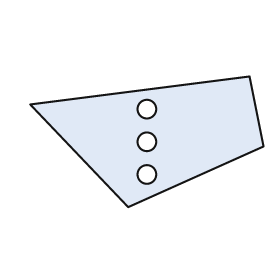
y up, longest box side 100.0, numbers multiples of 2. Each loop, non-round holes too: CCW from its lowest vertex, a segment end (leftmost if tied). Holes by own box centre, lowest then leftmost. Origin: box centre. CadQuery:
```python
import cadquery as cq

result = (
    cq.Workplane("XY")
    .moveTo(-8.0, -28.0)
    .lineTo(50.0, -2.0)
    .lineTo(44.0, 28.0)
    .lineTo(-50.0, 16.0)
    .close()
    .moveTo(0.0, -14.0)
    .circle(4.0)
    .moveTo(0.0, 0.0)
    .circle(4.0)
    .moveTo(0.0, 14.0)
    .circle(4.0)
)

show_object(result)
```